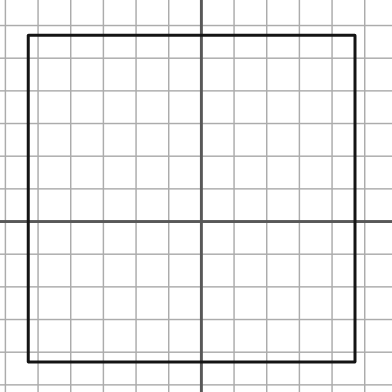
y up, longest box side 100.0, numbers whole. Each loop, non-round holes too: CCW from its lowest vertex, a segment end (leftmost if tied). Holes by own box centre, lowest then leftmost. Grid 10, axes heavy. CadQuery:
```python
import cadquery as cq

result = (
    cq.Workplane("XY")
    .moveTo(-53.0, -43.0)
    .lineTo(47.0, -43.0)
    .lineTo(47.0, 57.0)
    .lineTo(-53.0, 57.0)
    .close()
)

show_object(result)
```